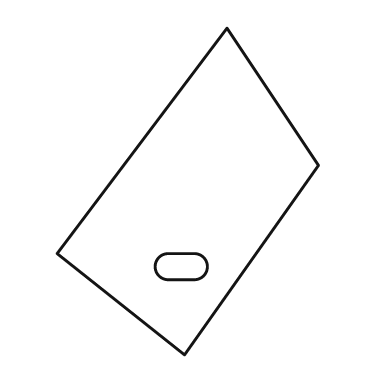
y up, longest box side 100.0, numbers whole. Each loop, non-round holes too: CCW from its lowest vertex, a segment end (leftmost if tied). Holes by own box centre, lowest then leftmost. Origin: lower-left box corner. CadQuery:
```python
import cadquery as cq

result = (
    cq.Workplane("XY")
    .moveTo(39.0, 0.0)
    .lineTo(80.0, 58.0)
    .lineTo(52.0, 100.0)
    .lineTo(0.0, 31.0)
    .close()
    .moveTo(34.0, 23.0)
    .lineTo(42.0, 23.0)
    .threePointArc((46.0, 27.0), (42.0, 31.0))
    .lineTo(34.0, 31.0)
    .threePointArc((30.0, 27.0), (34.0, 23.0))
    .close()
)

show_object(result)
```